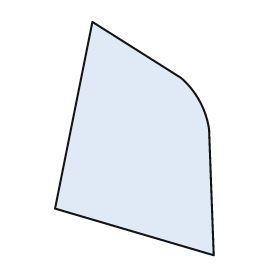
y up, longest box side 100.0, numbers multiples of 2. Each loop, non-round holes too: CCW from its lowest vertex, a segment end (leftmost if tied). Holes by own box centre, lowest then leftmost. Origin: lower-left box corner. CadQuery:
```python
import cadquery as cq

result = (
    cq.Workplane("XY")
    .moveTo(68.0, 0.0)
    .lineTo(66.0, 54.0)
    .threePointArc((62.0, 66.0), (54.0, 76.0))
    .lineTo(16.0, 100.0)
    .lineTo(0.0, 20.0)
    .close()
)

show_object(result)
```